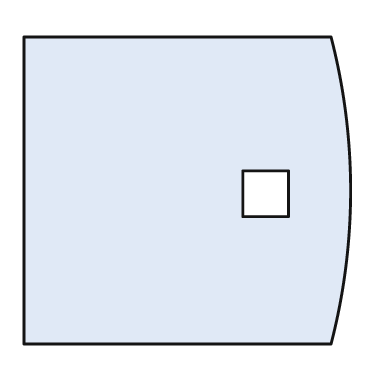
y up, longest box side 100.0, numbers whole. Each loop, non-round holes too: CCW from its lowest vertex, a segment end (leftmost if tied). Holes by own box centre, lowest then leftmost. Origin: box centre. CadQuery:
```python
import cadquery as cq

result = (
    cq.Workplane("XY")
    .moveTo(-50.0, -47.0)
    .lineTo(44.0, -47.0)
    .threePointArc((50.0, 0.0), (44.0, 47.0))
    .lineTo(-50.0, 47.0)
    .close()
    .moveTo(17.0, -8.0)
    .lineTo(31.0, -8.0)
    .lineTo(31.0, 6.0)
    .lineTo(17.0, 6.0)
    .close()
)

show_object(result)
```